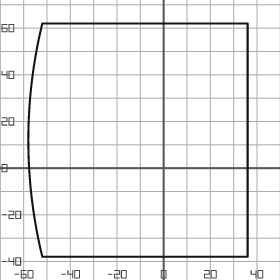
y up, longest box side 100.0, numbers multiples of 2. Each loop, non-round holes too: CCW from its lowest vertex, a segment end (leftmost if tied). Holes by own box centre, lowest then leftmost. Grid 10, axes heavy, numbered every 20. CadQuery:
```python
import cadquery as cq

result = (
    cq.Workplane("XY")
    .moveTo(-52.0, -38.0)
    .lineTo(36.0, -38.0)
    .lineTo(36.0, 62.0)
    .lineTo(-52.0, 62.0)
    .threePointArc((-58.0, 12.0), (-52.0, -38.0))
    .close()
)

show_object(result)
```